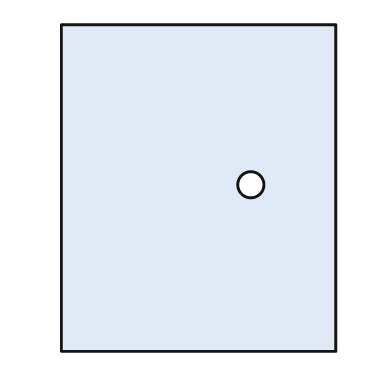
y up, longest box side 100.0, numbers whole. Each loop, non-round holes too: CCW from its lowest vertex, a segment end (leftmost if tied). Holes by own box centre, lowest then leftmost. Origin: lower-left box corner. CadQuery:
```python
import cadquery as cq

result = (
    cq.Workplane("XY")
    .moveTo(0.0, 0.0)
    .lineTo(84.0, 0.0)
    .lineTo(84.0, 100.0)
    .lineTo(0.0, 100.0)
    .close()
    .moveTo(58.0, 51.0)
    .circle(4.0)
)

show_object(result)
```